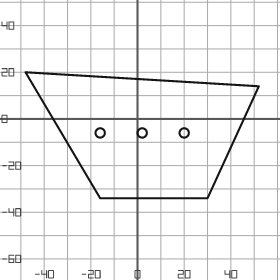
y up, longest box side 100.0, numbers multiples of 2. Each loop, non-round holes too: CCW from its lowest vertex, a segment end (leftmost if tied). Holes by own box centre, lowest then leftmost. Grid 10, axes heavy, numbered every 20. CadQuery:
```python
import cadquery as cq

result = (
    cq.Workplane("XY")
    .moveTo(-16.0, -34.0)
    .lineTo(30.0, -34.0)
    .lineTo(52.0, 14.0)
    .lineTo(-48.0, 20.0)
    .close()
    .moveTo(-16.0, -6.0)
    .circle(2.0)
    .moveTo(2.0, -6.0)
    .circle(2.0)
    .moveTo(20.0, -6.0)
    .circle(2.0)
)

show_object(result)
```